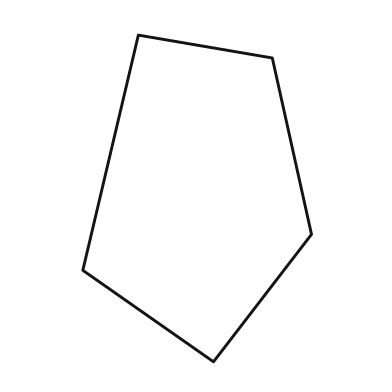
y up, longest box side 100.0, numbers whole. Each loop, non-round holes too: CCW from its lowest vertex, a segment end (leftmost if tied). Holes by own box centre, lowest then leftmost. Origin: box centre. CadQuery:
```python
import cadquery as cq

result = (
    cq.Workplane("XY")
    .moveTo(5.0, -50.0)
    .lineTo(35.0, -11.0)
    .lineTo(23.0, 43.0)
    .lineTo(-18.0, 50.0)
    .lineTo(-35.0, -22.0)
    .close()
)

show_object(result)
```